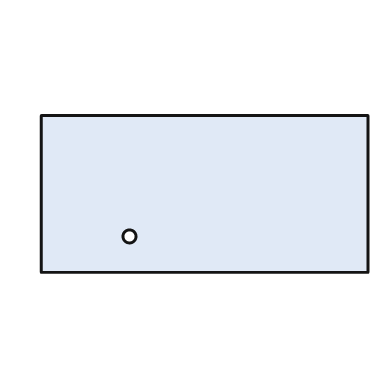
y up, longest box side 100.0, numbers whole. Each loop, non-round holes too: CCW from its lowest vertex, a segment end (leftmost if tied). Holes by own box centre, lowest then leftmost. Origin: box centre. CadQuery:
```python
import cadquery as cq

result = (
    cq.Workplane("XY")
    .moveTo(-50.0, -24.0)
    .lineTo(50.0, -24.0)
    .lineTo(50.0, 24.0)
    .lineTo(-50.0, 24.0)
    .close()
    .moveTo(-23.0, -13.0)
    .circle(2.0)
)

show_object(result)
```